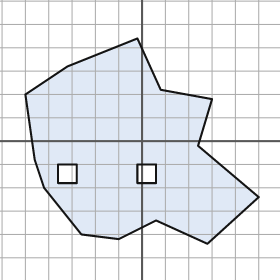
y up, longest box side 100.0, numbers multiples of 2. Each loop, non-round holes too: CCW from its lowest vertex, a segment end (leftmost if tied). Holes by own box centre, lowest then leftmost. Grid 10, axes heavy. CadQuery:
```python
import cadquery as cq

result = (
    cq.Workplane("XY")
    .moveTo(28.0, -44.0)
    .lineTo(50.0, -24.0)
    .lineTo(24.0, -2.0)
    .lineTo(30.0, 18.0)
    .lineTo(8.0, 22.0)
    .lineTo(-2.0, 44.0)
    .lineTo(-32.0, 32.0)
    .lineTo(-50.0, 20.0)
    .lineTo(-46.0, -8.0)
    .lineTo(-42.0, -20.0)
    .lineTo(-26.0, -40.0)
    .lineTo(-10.0, -42.0)
    .lineTo(6.0, -34.0)
    .close()
    .moveTo(-36.0, -18.0)
    .lineTo(-28.0, -18.0)
    .lineTo(-28.0, -10.0)
    .lineTo(-36.0, -10.0)
    .close()
    .moveTo(-2.0, -18.0)
    .lineTo(6.0, -18.0)
    .lineTo(6.0, -10.0)
    .lineTo(-2.0, -10.0)
    .close()
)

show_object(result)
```